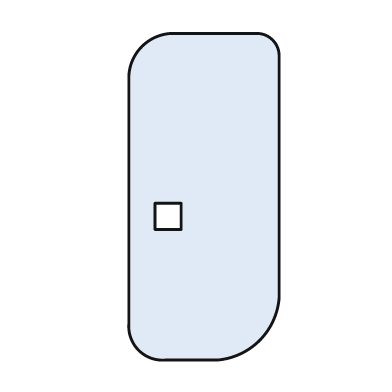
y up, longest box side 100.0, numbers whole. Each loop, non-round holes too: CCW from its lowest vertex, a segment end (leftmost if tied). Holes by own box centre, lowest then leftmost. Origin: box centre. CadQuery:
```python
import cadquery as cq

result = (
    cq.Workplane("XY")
    .moveTo(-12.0, -50.0)
    .lineTo(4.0, -50.0)
    .threePointArc((17.0, -44.0), (23.0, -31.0))
    .lineTo(23.0, 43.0)
    .threePointArc((21.0, 48.0), (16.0, 50.0))
    .lineTo(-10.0, 50.0)
    .threePointArc((-19.0, 46.0), (-23.0, 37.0))
    .lineTo(-23.0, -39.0)
    .threePointArc((-20.0, -47.0), (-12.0, -50.0))
    .close()
    .moveTo(-15.0, -10.0)
    .lineTo(-7.0, -10.0)
    .lineTo(-7.0, -2.0)
    .lineTo(-15.0, -2.0)
    .close()
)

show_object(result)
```